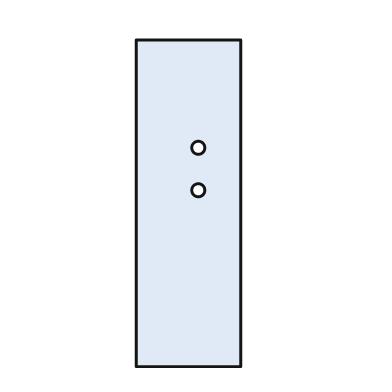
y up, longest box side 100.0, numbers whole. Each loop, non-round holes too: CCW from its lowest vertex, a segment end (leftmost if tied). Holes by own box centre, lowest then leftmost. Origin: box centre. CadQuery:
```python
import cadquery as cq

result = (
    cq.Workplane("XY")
    .moveTo(-16.0, -50.0)
    .lineTo(16.0, -50.0)
    .lineTo(16.0, 50.0)
    .lineTo(-16.0, 50.0)
    .close()
    .moveTo(3.0, 4.0)
    .circle(2.0)
    .moveTo(3.0, 17.0)
    .circle(2.0)
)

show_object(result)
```